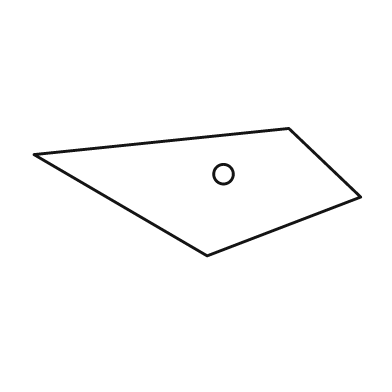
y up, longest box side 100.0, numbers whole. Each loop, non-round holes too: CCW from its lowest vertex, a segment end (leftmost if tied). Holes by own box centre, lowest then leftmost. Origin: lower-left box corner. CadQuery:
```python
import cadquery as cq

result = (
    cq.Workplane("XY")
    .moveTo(53.0, 0.0)
    .lineTo(100.0, 18.0)
    .lineTo(78.0, 39.0)
    .lineTo(0.0, 31.0)
    .close()
    .moveTo(58.0, 25.0)
    .circle(3.0)
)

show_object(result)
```